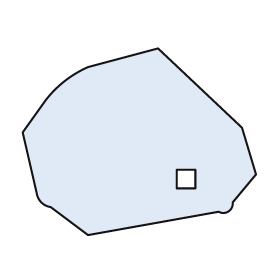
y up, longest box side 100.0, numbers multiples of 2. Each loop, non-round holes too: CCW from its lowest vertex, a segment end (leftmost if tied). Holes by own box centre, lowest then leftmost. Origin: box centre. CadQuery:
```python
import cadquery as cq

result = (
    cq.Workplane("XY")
    .moveTo(-22.0, -40.0)
    .lineTo(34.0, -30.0)
    .threePointArc((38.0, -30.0), (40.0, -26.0))
    .lineTo(50.0, -14.0)
    .lineTo(44.0, 6.0)
    .lineTo(8.0, 40.0)
    .lineTo(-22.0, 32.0)
    .threePointArc((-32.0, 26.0), (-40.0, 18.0))
    .lineTo(-50.0, 4.0)
    .lineTo(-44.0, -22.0)
    .threePointArc((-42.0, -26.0), (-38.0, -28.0))
    .close()
    .moveTo(16.0, -20.0)
    .lineTo(24.0, -20.0)
    .lineTo(24.0, -12.0)
    .lineTo(16.0, -12.0)
    .close()
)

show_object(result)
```